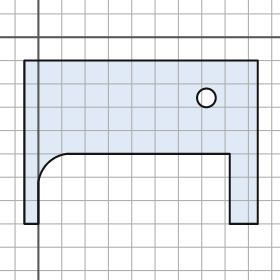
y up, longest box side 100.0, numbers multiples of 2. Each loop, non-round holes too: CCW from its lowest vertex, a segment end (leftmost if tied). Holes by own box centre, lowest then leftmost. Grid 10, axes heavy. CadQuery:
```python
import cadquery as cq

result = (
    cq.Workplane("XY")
    .moveTo(-6.0, -80.0)
    .lineTo(0.0, -80.0)
    .lineTo(0.0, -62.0)
    .threePointArc((4.0, -54.0), (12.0, -50.0))
    .lineTo(82.0, -50.0)
    .lineTo(82.0, -80.0)
    .lineTo(94.0, -80.0)
    .lineTo(94.0, -10.0)
    .lineTo(-6.0, -10.0)
    .close()
    .moveTo(72.0, -26.0)
    .circle(4.0)
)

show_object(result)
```